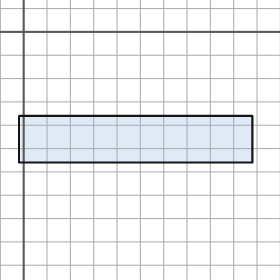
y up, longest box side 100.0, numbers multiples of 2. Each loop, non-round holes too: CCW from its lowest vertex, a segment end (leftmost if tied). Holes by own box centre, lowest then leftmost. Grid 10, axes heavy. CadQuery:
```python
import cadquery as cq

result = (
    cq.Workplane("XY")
    .moveTo(-2.0, -56.0)
    .lineTo(98.0, -56.0)
    .lineTo(98.0, -36.0)
    .lineTo(-2.0, -36.0)
    .close()
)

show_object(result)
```